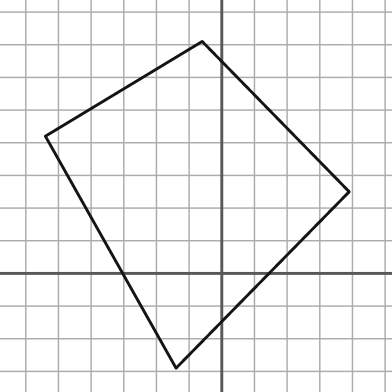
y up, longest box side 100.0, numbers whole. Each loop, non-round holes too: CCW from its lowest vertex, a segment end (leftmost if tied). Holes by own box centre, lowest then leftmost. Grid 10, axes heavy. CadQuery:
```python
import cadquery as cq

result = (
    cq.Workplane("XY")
    .moveTo(-14.0, -29.0)
    .lineTo(39.0, 25.0)
    .lineTo(-6.0, 71.0)
    .lineTo(-54.0, 42.0)
    .close()
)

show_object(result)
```